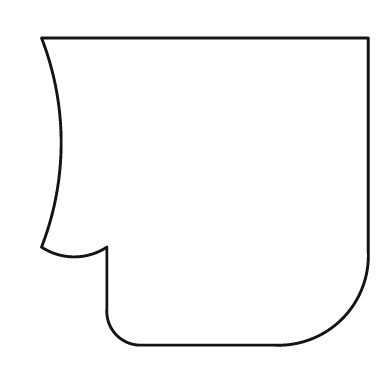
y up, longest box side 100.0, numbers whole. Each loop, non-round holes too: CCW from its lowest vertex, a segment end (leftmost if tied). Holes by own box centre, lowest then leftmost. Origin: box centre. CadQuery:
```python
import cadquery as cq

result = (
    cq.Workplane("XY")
    .moveTo(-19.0, -47.0)
    .lineTo(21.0, -47.0)
    .threePointArc((42.0, -39.0), (50.0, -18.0))
    .lineTo(50.0, 47.0)
    .lineTo(-50.0, 47.0)
    .threePointArc((-44.0, 15.0), (-50.0, -17.0))
    .threePointArc((-40.0, -20.0), (-30.0, -17.0))
    .lineTo(-30.0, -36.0)
    .threePointArc((-27.0, -44.0), (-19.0, -47.0))
    .close()
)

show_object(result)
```